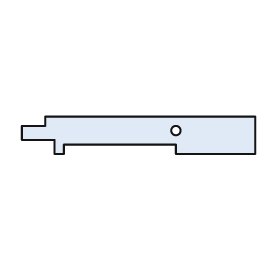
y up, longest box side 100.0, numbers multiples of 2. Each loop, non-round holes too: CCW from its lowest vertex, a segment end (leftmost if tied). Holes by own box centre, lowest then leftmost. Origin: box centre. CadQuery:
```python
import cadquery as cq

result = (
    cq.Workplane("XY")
    .moveTo(-36.0, -8.0)
    .lineTo(-32.0, -8.0)
    .lineTo(-32.0, -4.0)
    .lineTo(16.0, -4.0)
    .lineTo(16.0, -8.0)
    .lineTo(50.0, -8.0)
    .lineTo(50.0, 8.0)
    .lineTo(-40.0, 8.0)
    .lineTo(-40.0, 4.0)
    .lineTo(-50.0, 4.0)
    .lineTo(-50.0, -2.0)
    .lineTo(-36.0, -2.0)
    .close()
    .moveTo(16.0, 2.0)
    .circle(2.0)
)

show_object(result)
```